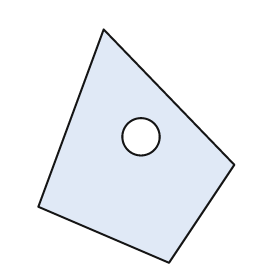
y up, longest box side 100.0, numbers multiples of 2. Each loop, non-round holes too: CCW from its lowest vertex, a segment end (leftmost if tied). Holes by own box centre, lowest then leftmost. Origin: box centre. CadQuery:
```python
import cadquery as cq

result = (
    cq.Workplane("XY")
    .moveTo(14.0, -50.0)
    .lineTo(42.0, -8.0)
    .lineTo(-14.0, 50.0)
    .lineTo(-42.0, -26.0)
    .close()
    .moveTo(2.0, 4.0)
    .circle(8.0)
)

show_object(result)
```